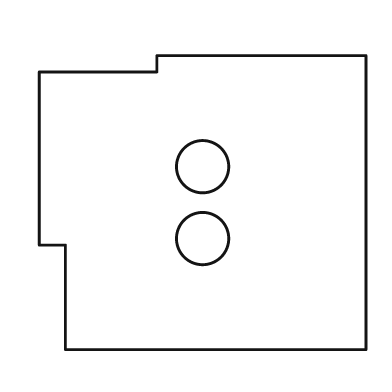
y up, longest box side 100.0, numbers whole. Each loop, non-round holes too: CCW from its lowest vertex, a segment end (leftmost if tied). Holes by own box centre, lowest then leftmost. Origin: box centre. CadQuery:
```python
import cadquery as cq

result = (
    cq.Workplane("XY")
    .moveTo(-42.0, -45.0)
    .lineTo(50.0, -45.0)
    .lineTo(50.0, 45.0)
    .lineTo(-14.0, 45.0)
    .lineTo(-14.0, 40.0)
    .lineTo(-50.0, 40.0)
    .lineTo(-50.0, -13.0)
    .lineTo(-42.0, -13.0)
    .close()
    .moveTo(0.0, -11.0)
    .circle(8.0)
    .moveTo(0.0, 11.0)
    .circle(8.0)
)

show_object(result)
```